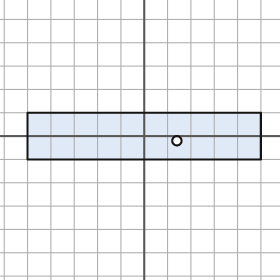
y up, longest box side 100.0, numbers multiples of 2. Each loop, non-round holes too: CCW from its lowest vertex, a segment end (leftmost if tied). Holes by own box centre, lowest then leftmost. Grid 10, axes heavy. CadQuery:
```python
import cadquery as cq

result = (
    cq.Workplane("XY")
    .moveTo(-50.0, -10.0)
    .lineTo(50.0, -10.0)
    .lineTo(50.0, 10.0)
    .lineTo(-50.0, 10.0)
    .close()
    .moveTo(14.0, -2.0)
    .circle(2.0)
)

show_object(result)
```